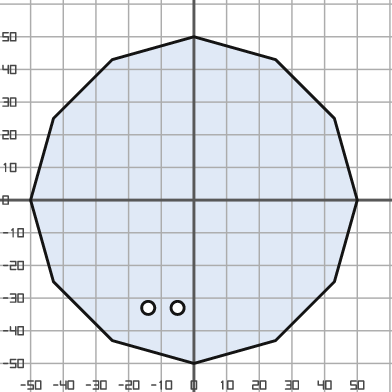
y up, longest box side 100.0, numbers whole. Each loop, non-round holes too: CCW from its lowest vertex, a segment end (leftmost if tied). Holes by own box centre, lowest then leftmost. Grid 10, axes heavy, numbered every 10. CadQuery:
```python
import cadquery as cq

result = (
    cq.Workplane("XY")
    .moveTo(0.0, -50.0)
    .lineTo(25.0, -43.0)
    .lineTo(43.0, -25.0)
    .lineTo(50.0, 0.0)
    .lineTo(43.0, 25.0)
    .lineTo(25.0, 43.0)
    .lineTo(0.0, 50.0)
    .lineTo(-25.0, 43.0)
    .lineTo(-43.0, 25.0)
    .lineTo(-50.0, 0.0)
    .lineTo(-43.0, -25.0)
    .lineTo(-25.0, -43.0)
    .close()
    .moveTo(-14.0, -33.0)
    .circle(2.0)
    .moveTo(-5.0, -33.0)
    .circle(2.0)
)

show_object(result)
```